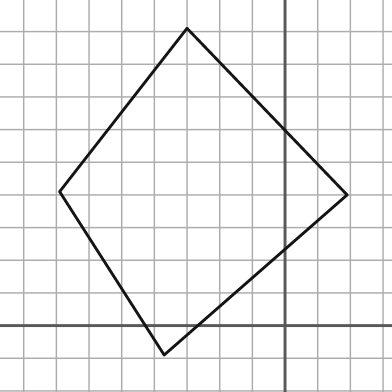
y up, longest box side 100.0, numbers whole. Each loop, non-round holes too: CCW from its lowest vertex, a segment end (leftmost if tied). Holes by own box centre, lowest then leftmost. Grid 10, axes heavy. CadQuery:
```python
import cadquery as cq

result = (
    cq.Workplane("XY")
    .moveTo(-37.0, -9.0)
    .lineTo(19.0, 40.0)
    .lineTo(-30.0, 91.0)
    .lineTo(-69.0, 41.0)
    .close()
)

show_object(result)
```